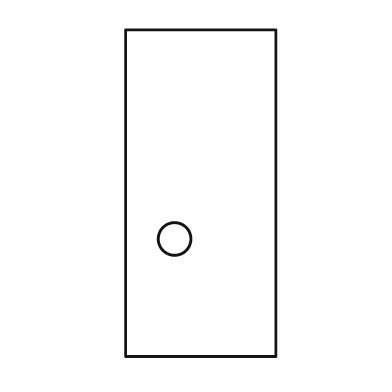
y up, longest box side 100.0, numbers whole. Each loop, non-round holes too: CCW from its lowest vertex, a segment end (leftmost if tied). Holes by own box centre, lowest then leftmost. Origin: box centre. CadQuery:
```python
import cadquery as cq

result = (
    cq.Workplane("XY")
    .moveTo(-23.0, -50.0)
    .lineTo(23.0, -50.0)
    .lineTo(23.0, 50.0)
    .lineTo(-23.0, 50.0)
    .close()
    .moveTo(-8.0, -14.0)
    .circle(5.0)
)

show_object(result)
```